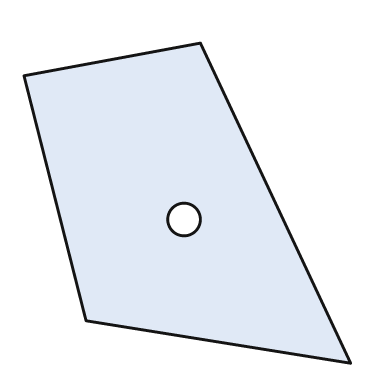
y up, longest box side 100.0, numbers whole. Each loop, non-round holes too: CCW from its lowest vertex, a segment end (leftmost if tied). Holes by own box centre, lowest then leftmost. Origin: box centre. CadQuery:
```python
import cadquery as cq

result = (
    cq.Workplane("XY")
    .moveTo(50.0, -49.0)
    .lineTo(4.0, 49.0)
    .lineTo(-50.0, 39.0)
    .lineTo(-31.0, -36.0)
    .close()
    .moveTo(-1.0, -5.0)
    .circle(5.0)
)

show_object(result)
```